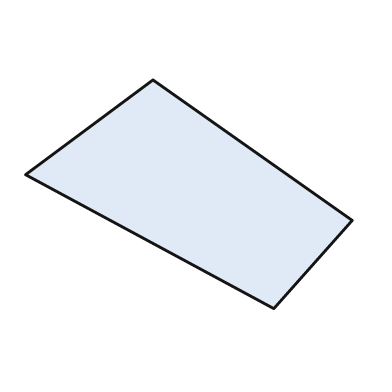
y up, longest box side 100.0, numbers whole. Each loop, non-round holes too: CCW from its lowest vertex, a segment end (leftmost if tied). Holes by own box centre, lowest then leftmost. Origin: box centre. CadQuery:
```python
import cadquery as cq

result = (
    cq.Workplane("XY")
    .moveTo(26.0, -35.0)
    .lineTo(50.0, -8.0)
    .lineTo(-11.0, 35.0)
    .lineTo(-50.0, 6.0)
    .close()
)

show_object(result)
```